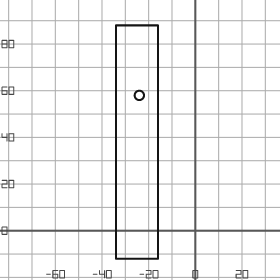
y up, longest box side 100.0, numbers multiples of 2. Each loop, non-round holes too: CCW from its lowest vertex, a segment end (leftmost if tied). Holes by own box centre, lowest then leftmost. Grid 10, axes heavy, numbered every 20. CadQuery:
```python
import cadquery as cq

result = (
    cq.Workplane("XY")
    .moveTo(-34.0, -12.0)
    .lineTo(-16.0, -12.0)
    .lineTo(-16.0, 88.0)
    .lineTo(-34.0, 88.0)
    .close()
    .moveTo(-24.0, 58.0)
    .circle(2.0)
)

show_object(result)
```